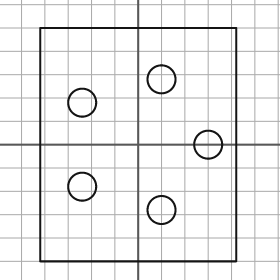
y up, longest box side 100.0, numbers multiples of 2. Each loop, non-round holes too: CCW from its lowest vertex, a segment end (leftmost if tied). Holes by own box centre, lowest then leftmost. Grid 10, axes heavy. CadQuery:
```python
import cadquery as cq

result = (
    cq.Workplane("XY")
    .moveTo(-42.0, -50.0)
    .lineTo(42.0, -50.0)
    .lineTo(42.0, 50.0)
    .lineTo(-42.0, 50.0)
    .close()
    .moveTo(10.0, -28.0)
    .circle(6.0)
    .moveTo(-24.0, -18.0)
    .circle(6.0)
    .moveTo(30.0, 0.0)
    .circle(6.0)
    .moveTo(-24.0, 18.0)
    .circle(6.0)
    .moveTo(10.0, 28.0)
    .circle(6.0)
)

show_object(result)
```